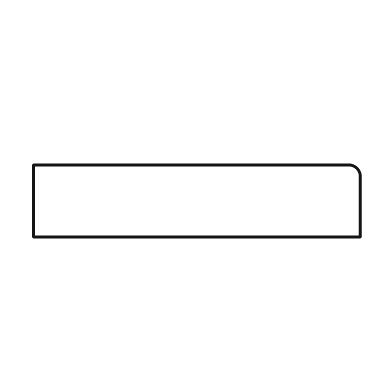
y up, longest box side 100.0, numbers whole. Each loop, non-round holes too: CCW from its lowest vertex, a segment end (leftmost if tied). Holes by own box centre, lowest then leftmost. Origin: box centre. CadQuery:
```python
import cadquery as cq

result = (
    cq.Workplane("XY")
    .moveTo(-50.0, -11.0)
    .lineTo(50.0, -11.0)
    .lineTo(50.0, 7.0)
    .threePointArc((49.0, 10.0), (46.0, 11.0))
    .lineTo(-50.0, 11.0)
    .close()
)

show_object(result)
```